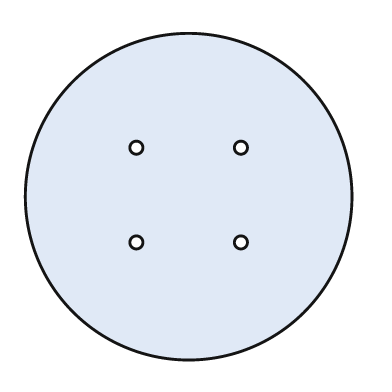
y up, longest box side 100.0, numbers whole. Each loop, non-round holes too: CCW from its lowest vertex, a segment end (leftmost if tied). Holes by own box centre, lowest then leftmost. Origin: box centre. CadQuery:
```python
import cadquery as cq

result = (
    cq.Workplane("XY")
    .moveTo(0.0, 0.0)
    .circle(50.0)
    .moveTo(-16.0, -14.0)
    .circle(2.0)
    .moveTo(16.0, -14.0)
    .circle(2.0)
    .moveTo(-16.0, 15.0)
    .circle(2.0)
    .moveTo(16.0, 15.0)
    .circle(2.0)
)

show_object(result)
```